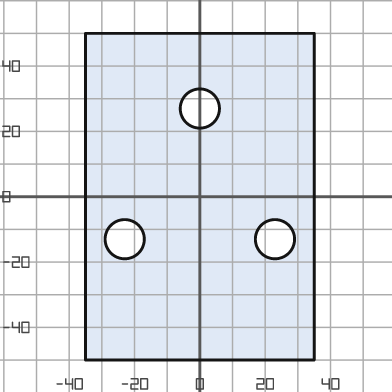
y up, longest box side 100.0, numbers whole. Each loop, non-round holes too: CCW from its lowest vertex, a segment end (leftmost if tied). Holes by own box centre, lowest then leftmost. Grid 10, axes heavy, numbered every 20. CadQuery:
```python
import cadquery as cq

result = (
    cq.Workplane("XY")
    .moveTo(-35.0, -50.0)
    .lineTo(35.0, -50.0)
    .lineTo(35.0, 50.0)
    .lineTo(-35.0, 50.0)
    .close()
    .moveTo(-23.0, -13.0)
    .circle(6.0)
    .moveTo(23.0, -13.0)
    .circle(6.0)
    .moveTo(0.0, 27.0)
    .circle(6.0)
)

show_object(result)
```